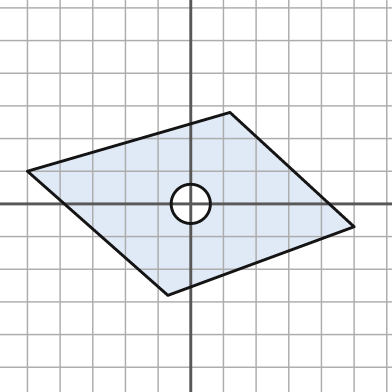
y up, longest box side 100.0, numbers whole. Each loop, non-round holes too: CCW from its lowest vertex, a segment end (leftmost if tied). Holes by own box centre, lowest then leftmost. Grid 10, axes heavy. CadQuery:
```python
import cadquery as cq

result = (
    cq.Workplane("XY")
    .moveTo(-7.0, -28.0)
    .lineTo(50.0, -7.0)
    .lineTo(12.0, 28.0)
    .lineTo(-50.0, 10.0)
    .close()
    .moveTo(0.0, 0.0)
    .circle(6.0)
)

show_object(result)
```